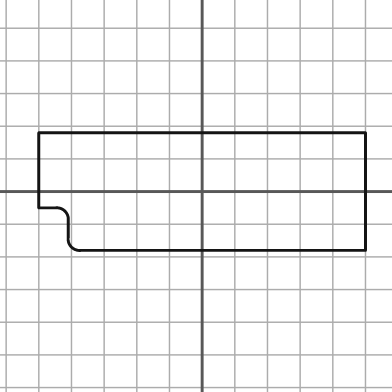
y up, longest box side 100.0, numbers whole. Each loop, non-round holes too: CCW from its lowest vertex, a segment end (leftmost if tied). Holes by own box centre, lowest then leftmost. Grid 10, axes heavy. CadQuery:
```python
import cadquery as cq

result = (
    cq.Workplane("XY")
    .moveTo(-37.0, -18.0)
    .lineTo(50.0, -18.0)
    .lineTo(50.0, 18.0)
    .lineTo(-50.0, 18.0)
    .lineTo(-50.0, -5.0)
    .lineTo(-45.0, -5.0)
    .threePointArc((-42.0, -6.0), (-41.0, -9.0))
    .lineTo(-41.0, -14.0)
    .threePointArc((-40.0, -17.0), (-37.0, -18.0))
    .close()
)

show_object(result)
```